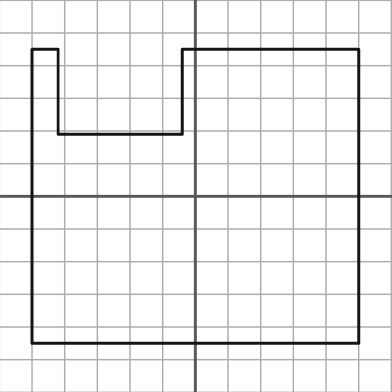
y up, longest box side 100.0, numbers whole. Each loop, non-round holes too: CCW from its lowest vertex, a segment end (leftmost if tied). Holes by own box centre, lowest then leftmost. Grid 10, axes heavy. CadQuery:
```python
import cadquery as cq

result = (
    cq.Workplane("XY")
    .moveTo(-50.0, -45.0)
    .lineTo(50.0, -45.0)
    .lineTo(50.0, 45.0)
    .lineTo(-4.0, 45.0)
    .lineTo(-4.0, 19.0)
    .lineTo(-42.0, 19.0)
    .lineTo(-42.0, 45.0)
    .lineTo(-50.0, 45.0)
    .close()
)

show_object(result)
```